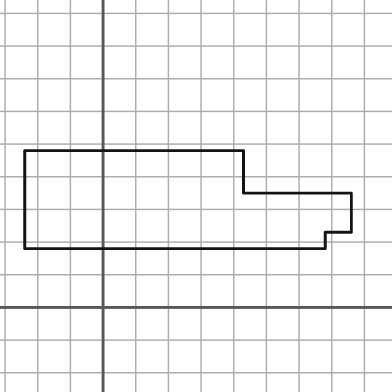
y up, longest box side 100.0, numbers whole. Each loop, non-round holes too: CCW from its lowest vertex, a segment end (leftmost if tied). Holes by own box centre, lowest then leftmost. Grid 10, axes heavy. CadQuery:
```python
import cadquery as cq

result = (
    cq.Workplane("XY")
    .moveTo(-24.0, 18.0)
    .lineTo(68.0, 18.0)
    .lineTo(68.0, 23.0)
    .lineTo(76.0, 23.0)
    .lineTo(76.0, 35.0)
    .lineTo(43.0, 35.0)
    .lineTo(43.0, 48.0)
    .lineTo(-24.0, 48.0)
    .close()
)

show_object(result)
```